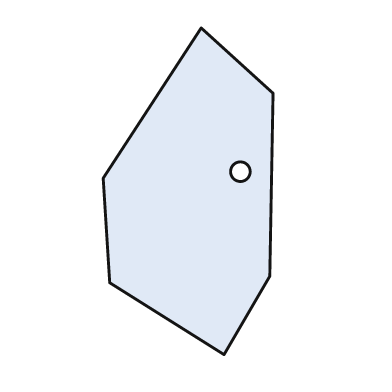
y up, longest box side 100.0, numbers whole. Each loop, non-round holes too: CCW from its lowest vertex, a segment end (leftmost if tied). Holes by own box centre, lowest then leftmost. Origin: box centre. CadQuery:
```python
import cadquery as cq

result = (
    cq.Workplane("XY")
    .moveTo(11.0, -50.0)
    .lineTo(25.0, -26.0)
    .lineTo(26.0, 30.0)
    .lineTo(4.0, 50.0)
    .lineTo(-26.0, 4.0)
    .lineTo(-24.0, -28.0)
    .close()
    .moveTo(16.0, 6.0)
    .circle(3.0)
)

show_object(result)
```